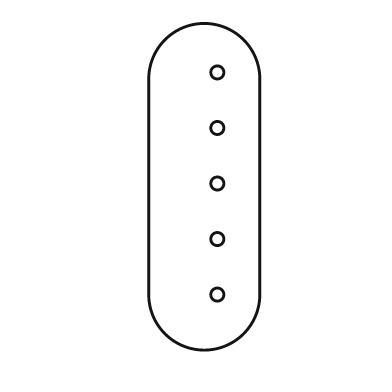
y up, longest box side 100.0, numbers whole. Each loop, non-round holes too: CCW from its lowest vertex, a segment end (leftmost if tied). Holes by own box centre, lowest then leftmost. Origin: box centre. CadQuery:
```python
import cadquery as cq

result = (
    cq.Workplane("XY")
    .moveTo(-17.0, -33.0)
    .threePointArc((0.0, -50.0), (17.0, -33.0))
    .lineTo(17.0, 33.0)
    .threePointArc((0.0, 50.0), (-17.0, 33.0))
    .close()
    .moveTo(4.0, -33.0)
    .circle(2.0)
    .moveTo(4.0, -16.0)
    .circle(2.0)
    .moveTo(4.0, 1.0)
    .circle(2.0)
    .moveTo(4.0, 18.0)
    .circle(2.0)
    .moveTo(4.0, 35.0)
    .circle(2.0)
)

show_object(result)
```